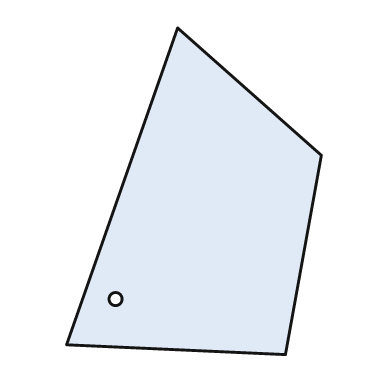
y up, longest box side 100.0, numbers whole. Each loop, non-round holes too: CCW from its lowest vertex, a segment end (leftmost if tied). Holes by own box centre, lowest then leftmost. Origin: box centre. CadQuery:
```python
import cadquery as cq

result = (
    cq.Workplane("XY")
    .moveTo(28.0, -50.0)
    .lineTo(39.0, 11.0)
    .lineTo(-5.0, 50.0)
    .lineTo(-39.0, -47.0)
    .close()
    .moveTo(-24.0, -33.0)
    .circle(2.0)
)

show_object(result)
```